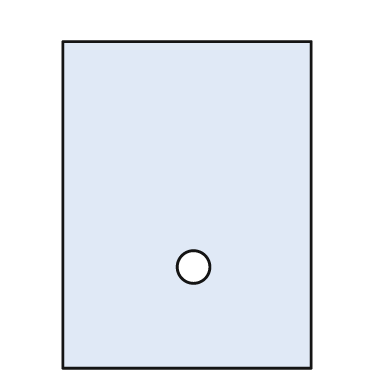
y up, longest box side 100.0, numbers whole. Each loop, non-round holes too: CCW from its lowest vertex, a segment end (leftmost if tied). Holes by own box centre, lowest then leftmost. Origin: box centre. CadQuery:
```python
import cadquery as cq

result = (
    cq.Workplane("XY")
    .moveTo(-38.0, -50.0)
    .lineTo(38.0, -50.0)
    .lineTo(38.0, 50.0)
    .lineTo(-38.0, 50.0)
    .close()
    .moveTo(2.0, -19.0)
    .circle(5.0)
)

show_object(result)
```